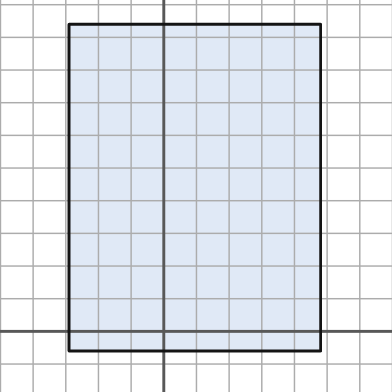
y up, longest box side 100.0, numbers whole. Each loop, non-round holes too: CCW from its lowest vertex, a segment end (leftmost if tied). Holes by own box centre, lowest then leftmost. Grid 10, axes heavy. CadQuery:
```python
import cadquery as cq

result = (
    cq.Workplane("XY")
    .moveTo(-29.0, -6.0)
    .lineTo(48.0, -6.0)
    .lineTo(48.0, 94.0)
    .lineTo(-29.0, 94.0)
    .close()
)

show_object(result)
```